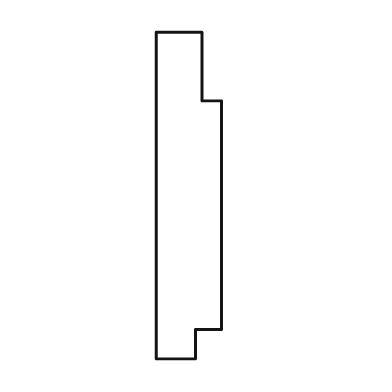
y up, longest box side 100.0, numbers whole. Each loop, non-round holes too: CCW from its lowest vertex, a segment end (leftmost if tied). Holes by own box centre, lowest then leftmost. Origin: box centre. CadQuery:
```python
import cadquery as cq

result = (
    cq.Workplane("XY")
    .moveTo(-10.0, -50.0)
    .lineTo(2.0, -50.0)
    .lineTo(2.0, -41.0)
    .lineTo(10.0, -41.0)
    .lineTo(10.0, 29.0)
    .lineTo(4.0, 29.0)
    .lineTo(4.0, 50.0)
    .lineTo(-10.0, 50.0)
    .close()
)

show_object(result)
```